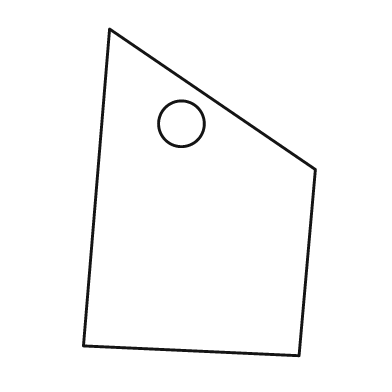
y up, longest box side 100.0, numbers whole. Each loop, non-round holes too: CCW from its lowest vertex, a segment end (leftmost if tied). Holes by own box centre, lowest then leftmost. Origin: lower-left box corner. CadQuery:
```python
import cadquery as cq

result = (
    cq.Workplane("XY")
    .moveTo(66.0, 0.0)
    .lineTo(71.0, 57.0)
    .lineTo(8.0, 100.0)
    .lineTo(0.0, 3.0)
    .close()
    .moveTo(30.0, 71.0)
    .circle(7.0)
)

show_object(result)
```